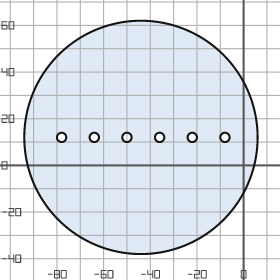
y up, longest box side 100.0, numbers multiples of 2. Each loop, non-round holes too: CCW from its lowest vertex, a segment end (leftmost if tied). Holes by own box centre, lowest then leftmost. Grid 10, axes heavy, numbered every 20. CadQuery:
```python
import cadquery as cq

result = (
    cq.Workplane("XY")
    .moveTo(-44.0, 12.0)
    .circle(50.0)
    .moveTo(-78.0, 12.0)
    .circle(2.0)
    .moveTo(-64.0, 12.0)
    .circle(2.0)
    .moveTo(-50.0, 12.0)
    .circle(2.0)
    .moveTo(-36.0, 12.0)
    .circle(2.0)
    .moveTo(-22.0, 12.0)
    .circle(2.0)
    .moveTo(-8.0, 12.0)
    .circle(2.0)
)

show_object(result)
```